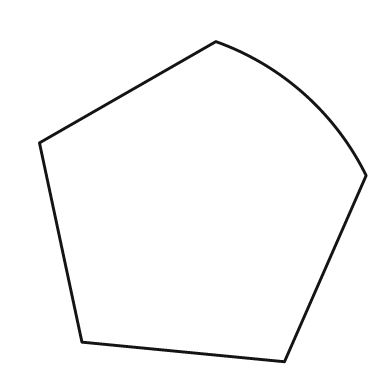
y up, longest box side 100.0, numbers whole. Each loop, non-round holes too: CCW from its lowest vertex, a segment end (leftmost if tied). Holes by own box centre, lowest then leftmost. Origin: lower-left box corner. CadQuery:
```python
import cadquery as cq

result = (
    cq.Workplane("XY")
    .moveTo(75.0, 0.0)
    .lineTo(100.0, 57.0)
    .threePointArc((81.0, 82.0), (54.0, 98.0))
    .lineTo(0.0, 67.0)
    .lineTo(13.0, 6.0)
    .close()
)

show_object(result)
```